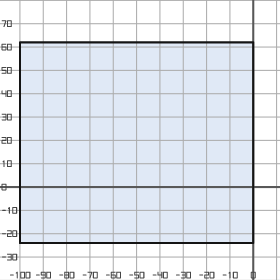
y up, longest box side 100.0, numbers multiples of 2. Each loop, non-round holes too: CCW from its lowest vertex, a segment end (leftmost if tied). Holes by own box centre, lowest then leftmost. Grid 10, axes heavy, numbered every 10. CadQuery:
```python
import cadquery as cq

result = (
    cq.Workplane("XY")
    .moveTo(-100.0, -24.0)
    .lineTo(0.0, -24.0)
    .lineTo(0.0, 62.0)
    .lineTo(-100.0, 62.0)
    .close()
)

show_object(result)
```